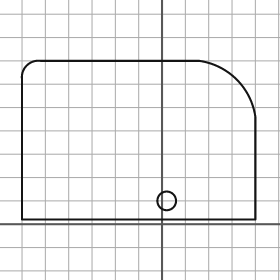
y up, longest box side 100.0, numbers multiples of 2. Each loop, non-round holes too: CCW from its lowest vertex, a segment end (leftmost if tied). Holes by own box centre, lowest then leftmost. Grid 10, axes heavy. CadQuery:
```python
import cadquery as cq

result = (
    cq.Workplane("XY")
    .moveTo(-60.0, 2.0)
    .lineTo(40.0, 2.0)
    .lineTo(40.0, 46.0)
    .threePointArc((32.0, 62.0), (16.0, 70.0))
    .lineTo(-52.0, 70.0)
    .threePointArc((-58.0, 68.0), (-60.0, 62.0))
    .close()
    .moveTo(2.0, 10.0)
    .circle(4.0)
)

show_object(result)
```